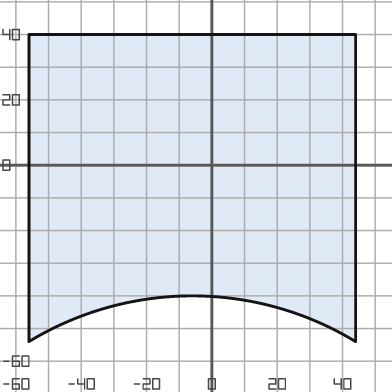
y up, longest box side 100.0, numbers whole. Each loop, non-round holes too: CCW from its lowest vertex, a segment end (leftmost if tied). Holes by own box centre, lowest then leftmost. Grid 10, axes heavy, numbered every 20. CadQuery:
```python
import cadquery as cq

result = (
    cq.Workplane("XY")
    .moveTo(-56.0, -54.0)
    .threePointArc((-6.0, -40.0), (44.0, -54.0))
    .lineTo(44.0, 40.0)
    .lineTo(-56.0, 40.0)
    .close()
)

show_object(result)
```